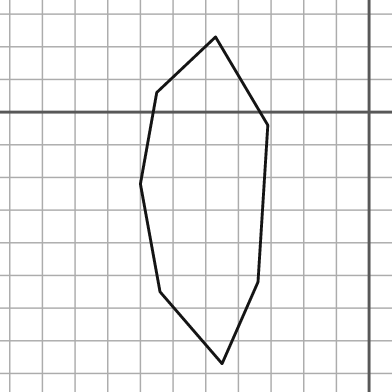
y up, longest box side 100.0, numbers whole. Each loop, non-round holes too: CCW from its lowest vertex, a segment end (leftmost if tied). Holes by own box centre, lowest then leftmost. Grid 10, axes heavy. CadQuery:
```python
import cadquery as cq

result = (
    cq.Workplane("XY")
    .moveTo(-45.0, -77.0)
    .lineTo(-34.0, -52.0)
    .lineTo(-31.0, -4.0)
    .lineTo(-47.0, 23.0)
    .lineTo(-65.0, 6.0)
    .lineTo(-70.0, -22.0)
    .lineTo(-64.0, -55.0)
    .close()
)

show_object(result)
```